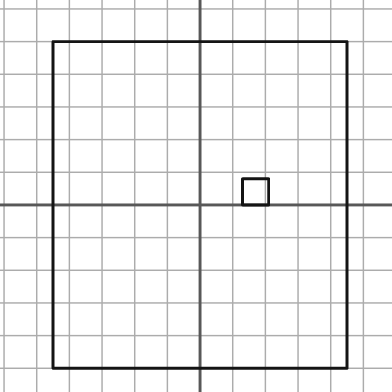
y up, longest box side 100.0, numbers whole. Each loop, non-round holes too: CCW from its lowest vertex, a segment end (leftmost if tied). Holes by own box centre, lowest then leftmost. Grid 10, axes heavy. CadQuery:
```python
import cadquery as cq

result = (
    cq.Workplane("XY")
    .moveTo(-45.0, -50.0)
    .lineTo(45.0, -50.0)
    .lineTo(45.0, 50.0)
    .lineTo(-45.0, 50.0)
    .close()
    .moveTo(13.0, 0.0)
    .lineTo(21.0, 0.0)
    .lineTo(21.0, 8.0)
    .lineTo(13.0, 8.0)
    .close()
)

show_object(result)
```